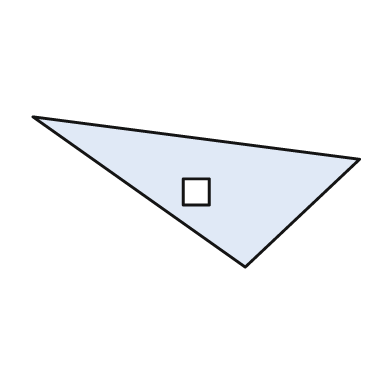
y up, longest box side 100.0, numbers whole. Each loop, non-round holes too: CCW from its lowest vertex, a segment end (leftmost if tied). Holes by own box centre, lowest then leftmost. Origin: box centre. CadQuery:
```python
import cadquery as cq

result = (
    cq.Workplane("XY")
    .moveTo(15.0, -23.0)
    .lineTo(50.0, 10.0)
    .lineTo(-50.0, 23.0)
    .close()
    .moveTo(-4.0, -4.0)
    .lineTo(4.0, -4.0)
    .lineTo(4.0, 4.0)
    .lineTo(-4.0, 4.0)
    .close()
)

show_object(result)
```